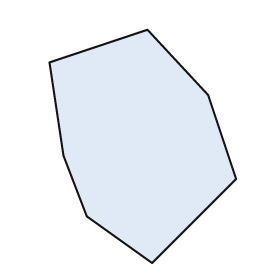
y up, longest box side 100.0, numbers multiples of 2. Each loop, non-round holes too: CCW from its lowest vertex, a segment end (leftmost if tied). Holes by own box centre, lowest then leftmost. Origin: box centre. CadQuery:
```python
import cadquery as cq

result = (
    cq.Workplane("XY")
    .moveTo(4.0, -50.0)
    .lineTo(40.0, -14.0)
    .lineTo(28.0, 22.0)
    .lineTo(2.0, 50.0)
    .lineTo(-40.0, 36.0)
    .lineTo(-34.0, -4.0)
    .lineTo(-24.0, -30.0)
    .close()
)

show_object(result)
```